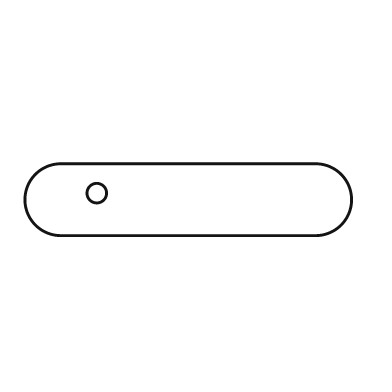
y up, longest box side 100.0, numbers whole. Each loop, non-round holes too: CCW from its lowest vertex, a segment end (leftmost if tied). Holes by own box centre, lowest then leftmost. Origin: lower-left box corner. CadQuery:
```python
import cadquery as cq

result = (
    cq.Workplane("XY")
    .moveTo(11.0, 0.0)
    .lineTo(89.0, 0.0)
    .threePointArc((100.0, 11.0), (89.0, 22.0))
    .lineTo(11.0, 22.0)
    .threePointArc((0.0, 11.0), (11.0, 0.0))
    .close()
    .moveTo(22.0, 13.0)
    .circle(3.0)
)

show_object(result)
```